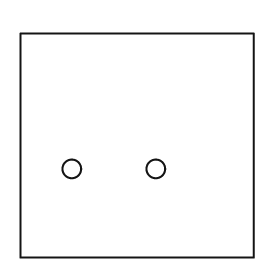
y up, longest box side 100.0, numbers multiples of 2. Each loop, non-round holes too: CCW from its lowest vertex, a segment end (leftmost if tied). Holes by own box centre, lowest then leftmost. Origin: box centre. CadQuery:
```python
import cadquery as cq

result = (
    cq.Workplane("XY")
    .moveTo(-50.0, -48.0)
    .lineTo(50.0, -48.0)
    .lineTo(50.0, 48.0)
    .lineTo(-50.0, 48.0)
    .close()
    .moveTo(-28.0, -10.0)
    .circle(4.0)
    .moveTo(8.0, -10.0)
    .circle(4.0)
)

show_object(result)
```